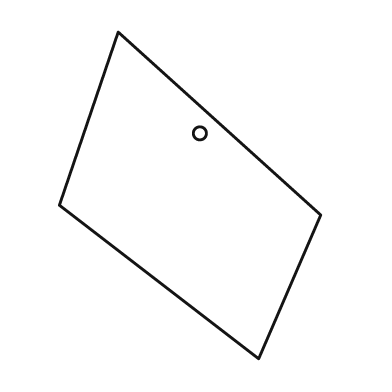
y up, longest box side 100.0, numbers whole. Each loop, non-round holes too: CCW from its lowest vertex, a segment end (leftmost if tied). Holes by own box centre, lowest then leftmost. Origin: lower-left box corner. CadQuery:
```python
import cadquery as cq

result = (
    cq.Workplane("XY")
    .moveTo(61.0, 0.0)
    .lineTo(80.0, 44.0)
    .lineTo(18.0, 100.0)
    .lineTo(0.0, 47.0)
    .close()
    .moveTo(43.0, 69.0)
    .circle(2.0)
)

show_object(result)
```